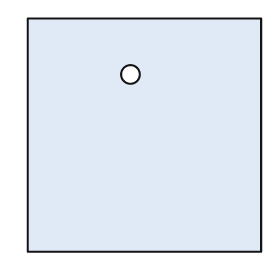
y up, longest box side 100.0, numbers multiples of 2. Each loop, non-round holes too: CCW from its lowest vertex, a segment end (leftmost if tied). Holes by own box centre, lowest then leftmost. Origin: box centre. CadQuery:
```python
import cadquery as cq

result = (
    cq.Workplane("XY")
    .moveTo(-50.0, -50.0)
    .lineTo(50.0, -50.0)
    .lineTo(50.0, 50.0)
    .lineTo(-50.0, 50.0)
    .close()
    .moveTo(-6.0, 26.0)
    .circle(4.0)
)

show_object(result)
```